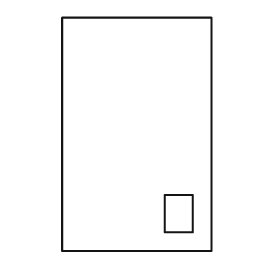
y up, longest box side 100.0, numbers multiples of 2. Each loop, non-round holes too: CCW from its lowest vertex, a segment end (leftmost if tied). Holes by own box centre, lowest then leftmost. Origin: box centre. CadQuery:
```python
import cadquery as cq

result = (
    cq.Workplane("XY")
    .moveTo(-32.0, -50.0)
    .lineTo(32.0, -50.0)
    .lineTo(32.0, 50.0)
    .lineTo(-32.0, 50.0)
    .close()
    .moveTo(12.0, -42.0)
    .lineTo(24.0, -42.0)
    .lineTo(24.0, -26.0)
    .lineTo(12.0, -26.0)
    .close()
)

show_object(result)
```